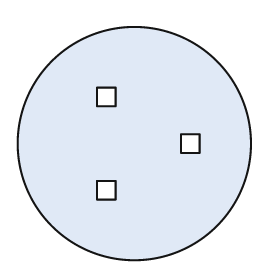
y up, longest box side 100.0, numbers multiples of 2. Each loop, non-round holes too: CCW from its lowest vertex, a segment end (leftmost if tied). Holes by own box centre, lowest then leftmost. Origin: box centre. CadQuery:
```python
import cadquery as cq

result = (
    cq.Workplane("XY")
    .moveTo(0.0, 0.0)
    .circle(50.0)
    .moveTo(-16.0, -24.0)
    .lineTo(-8.0, -24.0)
    .lineTo(-8.0, -16.0)
    .lineTo(-16.0, -16.0)
    .close()
    .moveTo(20.0, -4.0)
    .lineTo(28.0, -4.0)
    .lineTo(28.0, 4.0)
    .lineTo(20.0, 4.0)
    .close()
    .moveTo(-16.0, 16.0)
    .lineTo(-8.0, 16.0)
    .lineTo(-8.0, 24.0)
    .lineTo(-16.0, 24.0)
    .close()
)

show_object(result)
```